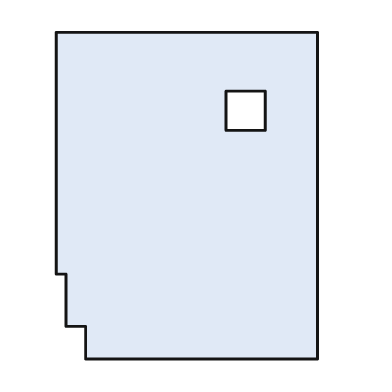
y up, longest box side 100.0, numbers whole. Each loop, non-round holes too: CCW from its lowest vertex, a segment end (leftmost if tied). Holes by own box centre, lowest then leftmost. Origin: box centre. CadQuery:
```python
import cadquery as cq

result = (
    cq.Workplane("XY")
    .moveTo(-31.0, -50.0)
    .lineTo(40.0, -50.0)
    .lineTo(40.0, 50.0)
    .lineTo(-40.0, 50.0)
    .lineTo(-40.0, -24.0)
    .lineTo(-37.0, -24.0)
    .lineTo(-37.0, -40.0)
    .lineTo(-31.0, -40.0)
    .close()
    .moveTo(12.0, 20.0)
    .lineTo(24.0, 20.0)
    .lineTo(24.0, 32.0)
    .lineTo(12.0, 32.0)
    .close()
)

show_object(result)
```